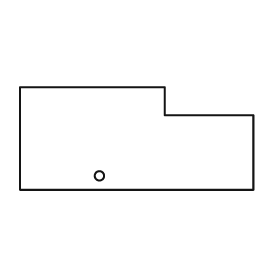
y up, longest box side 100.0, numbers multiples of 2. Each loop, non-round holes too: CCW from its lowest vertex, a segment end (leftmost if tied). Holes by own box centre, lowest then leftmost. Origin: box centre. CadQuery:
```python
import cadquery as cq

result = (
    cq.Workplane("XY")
    .moveTo(-50.0, -22.0)
    .lineTo(50.0, -22.0)
    .lineTo(50.0, 10.0)
    .lineTo(12.0, 10.0)
    .lineTo(12.0, 22.0)
    .lineTo(-50.0, 22.0)
    .close()
    .moveTo(-16.0, -16.0)
    .circle(2.0)
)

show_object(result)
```